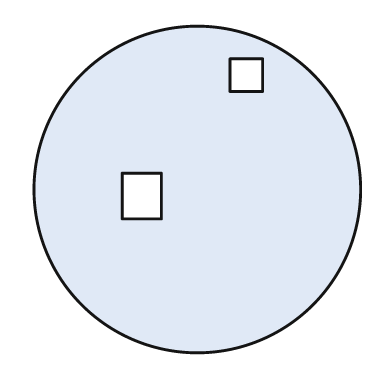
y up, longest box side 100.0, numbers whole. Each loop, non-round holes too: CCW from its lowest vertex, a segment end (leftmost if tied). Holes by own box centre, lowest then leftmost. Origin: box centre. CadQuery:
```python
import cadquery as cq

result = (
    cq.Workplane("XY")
    .moveTo(0.0, 0.0)
    .circle(50.0)
    .moveTo(-23.0, -9.0)
    .lineTo(-11.0, -9.0)
    .lineTo(-11.0, 5.0)
    .lineTo(-23.0, 5.0)
    .close()
    .moveTo(10.0, 30.0)
    .lineTo(20.0, 30.0)
    .lineTo(20.0, 40.0)
    .lineTo(10.0, 40.0)
    .close()
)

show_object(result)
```